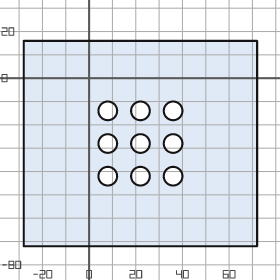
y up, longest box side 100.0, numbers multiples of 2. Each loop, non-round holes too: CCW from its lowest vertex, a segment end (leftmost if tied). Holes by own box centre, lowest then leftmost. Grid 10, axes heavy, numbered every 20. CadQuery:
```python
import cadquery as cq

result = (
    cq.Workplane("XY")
    .moveTo(-28.0, -72.0)
    .lineTo(72.0, -72.0)
    .lineTo(72.0, 16.0)
    .lineTo(-28.0, 16.0)
    .close()
    .moveTo(8.0, -42.0)
    .circle(4.0)
    .moveTo(22.0, -42.0)
    .circle(4.0)
    .moveTo(36.0, -42.0)
    .circle(4.0)
    .moveTo(8.0, -28.0)
    .circle(4.0)
    .moveTo(22.0, -28.0)
    .circle(4.0)
    .moveTo(36.0, -28.0)
    .circle(4.0)
    .moveTo(8.0, -14.0)
    .circle(4.0)
    .moveTo(22.0, -14.0)
    .circle(4.0)
    .moveTo(36.0, -14.0)
    .circle(4.0)
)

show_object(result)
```